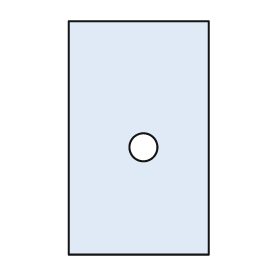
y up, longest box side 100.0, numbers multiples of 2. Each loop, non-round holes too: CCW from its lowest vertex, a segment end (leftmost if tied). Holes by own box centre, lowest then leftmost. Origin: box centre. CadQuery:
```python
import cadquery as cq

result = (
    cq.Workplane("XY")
    .moveTo(-30.0, -50.0)
    .lineTo(30.0, -50.0)
    .lineTo(30.0, 50.0)
    .lineTo(-30.0, 50.0)
    .close()
    .moveTo(2.0, -4.0)
    .circle(6.0)
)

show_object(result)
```